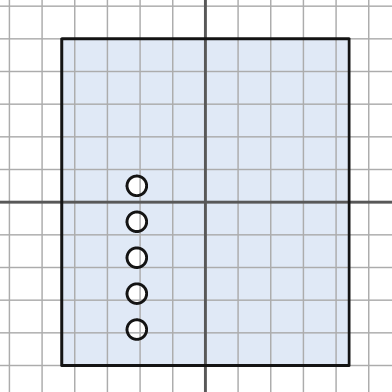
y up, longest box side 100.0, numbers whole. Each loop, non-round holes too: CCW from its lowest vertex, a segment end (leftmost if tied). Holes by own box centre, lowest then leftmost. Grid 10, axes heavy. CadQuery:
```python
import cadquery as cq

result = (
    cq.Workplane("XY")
    .moveTo(-44.0, -50.0)
    .lineTo(44.0, -50.0)
    .lineTo(44.0, 50.0)
    .lineTo(-44.0, 50.0)
    .close()
    .moveTo(-21.0, -39.0)
    .circle(3.0)
    .moveTo(-21.0, -28.0)
    .circle(3.0)
    .moveTo(-21.0, -17.0)
    .circle(3.0)
    .moveTo(-21.0, -6.0)
    .circle(3.0)
    .moveTo(-21.0, 5.0)
    .circle(3.0)
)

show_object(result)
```